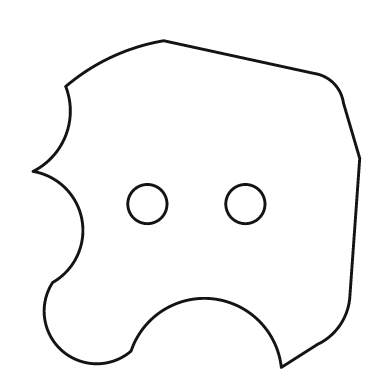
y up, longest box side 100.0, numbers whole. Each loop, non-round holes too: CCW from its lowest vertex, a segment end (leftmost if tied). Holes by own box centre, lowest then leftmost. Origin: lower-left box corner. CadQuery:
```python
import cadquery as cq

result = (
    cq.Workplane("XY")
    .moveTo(76.0, 0.0)
    .lineTo(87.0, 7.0)
    .threePointArc((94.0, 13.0), (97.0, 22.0))
    .lineTo(100.0, 64.0)
    .lineTo(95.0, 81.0)
    .threePointArc((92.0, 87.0), (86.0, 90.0))
    .lineTo(40.0, 100.0)
    .threePointArc((24.0, 95.0), (10.0, 86.0))
    .threePointArc((10.0, 71.0), (0.0, 60.0))
    .threePointArc((15.0, 45.0), (6.0, 26.0))
    .threePointArc((9.0, 5.0), (30.0, 5.0))
    .threePointArc((55.0, 21.0), (76.0, 0.0))
    .close()
    .moveTo(35.0, 50.0)
    .circle(6.0)
    .moveTo(65.0, 50.0)
    .circle(6.0)
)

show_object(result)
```